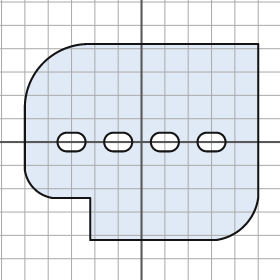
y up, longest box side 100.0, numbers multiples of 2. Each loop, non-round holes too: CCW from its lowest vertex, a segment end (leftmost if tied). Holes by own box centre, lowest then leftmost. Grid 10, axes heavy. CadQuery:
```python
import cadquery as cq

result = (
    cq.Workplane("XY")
    .moveTo(-22.0, -42.0)
    .lineTo(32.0, -42.0)
    .threePointArc((44.0, -36.0), (50.0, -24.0))
    .lineTo(50.0, 42.0)
    .lineTo(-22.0, 42.0)
    .threePointArc((-42.0, 34.0), (-50.0, 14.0))
    .lineTo(-50.0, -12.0)
    .threePointArc((-46.0, -20.0), (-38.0, -24.0))
    .lineTo(-22.0, -24.0)
    .close()
    .moveTo(-32.0, -4.0)
    .lineTo(-28.0, -4.0)
    .threePointArc((-24.0, 0.0), (-28.0, 4.0))
    .lineTo(-32.0, 4.0)
    .threePointArc((-36.0, 0.0), (-32.0, -4.0))
    .close()
    .moveTo(-12.0, -4.0)
    .lineTo(-8.0, -4.0)
    .threePointArc((-4.0, 0.0), (-8.0, 4.0))
    .lineTo(-12.0, 4.0)
    .threePointArc((-16.0, 0.0), (-12.0, -4.0))
    .close()
    .moveTo(8.0, -4.0)
    .lineTo(12.0, -4.0)
    .threePointArc((16.0, 0.0), (12.0, 4.0))
    .lineTo(8.0, 4.0)
    .threePointArc((4.0, 0.0), (8.0, -4.0))
    .close()
    .moveTo(28.0, -4.0)
    .lineTo(32.0, -4.0)
    .threePointArc((36.0, 0.0), (32.0, 4.0))
    .lineTo(28.0, 4.0)
    .threePointArc((24.0, 0.0), (28.0, -4.0))
    .close()
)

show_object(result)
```